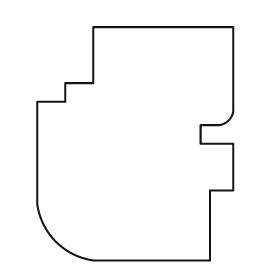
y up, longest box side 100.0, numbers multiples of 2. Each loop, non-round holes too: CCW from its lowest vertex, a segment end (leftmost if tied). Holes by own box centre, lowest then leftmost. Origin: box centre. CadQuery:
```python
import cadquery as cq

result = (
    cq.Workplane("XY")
    .moveTo(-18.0, -50.0)
    .lineTo(32.0, -50.0)
    .lineTo(32.0, -20.0)
    .lineTo(42.0, -20.0)
    .lineTo(42.0, 0.0)
    .lineTo(28.0, 0.0)
    .lineTo(28.0, 8.0)
    .lineTo(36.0, 8.0)
    .threePointArc((40.0, 10.0), (42.0, 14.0))
    .lineTo(42.0, 50.0)
    .lineTo(-18.0, 50.0)
    .lineTo(-18.0, 26.0)
    .lineTo(-30.0, 26.0)
    .lineTo(-30.0, 18.0)
    .lineTo(-42.0, 18.0)
    .lineTo(-42.0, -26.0)
    .threePointArc((-34.0, -42.0), (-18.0, -50.0))
    .close()
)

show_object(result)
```